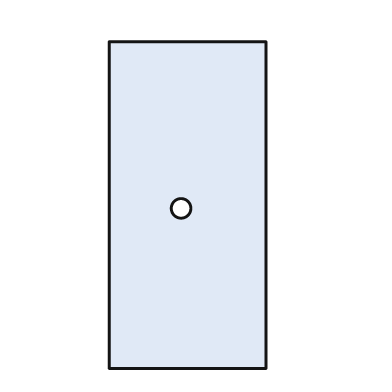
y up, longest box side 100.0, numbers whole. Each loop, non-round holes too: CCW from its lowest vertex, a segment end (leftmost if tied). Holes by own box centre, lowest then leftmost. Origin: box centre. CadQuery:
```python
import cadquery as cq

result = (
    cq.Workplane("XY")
    .moveTo(-24.0, -50.0)
    .lineTo(24.0, -50.0)
    .lineTo(24.0, 50.0)
    .lineTo(-24.0, 50.0)
    .close()
    .moveTo(-2.0, -1.0)
    .circle(3.0)
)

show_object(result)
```